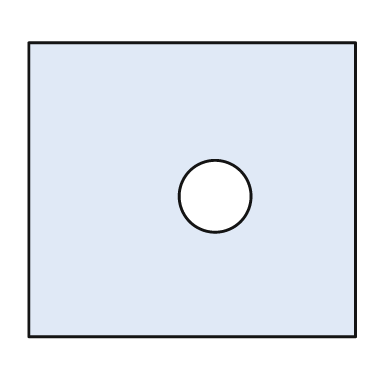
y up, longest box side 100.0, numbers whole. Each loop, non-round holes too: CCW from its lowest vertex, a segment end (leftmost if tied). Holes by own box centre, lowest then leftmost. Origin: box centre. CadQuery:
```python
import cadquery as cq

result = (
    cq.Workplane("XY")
    .moveTo(-50.0, -45.0)
    .lineTo(50.0, -45.0)
    .lineTo(50.0, 45.0)
    .lineTo(-50.0, 45.0)
    .close()
    .moveTo(7.0, -2.0)
    .circle(11.0)
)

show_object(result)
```